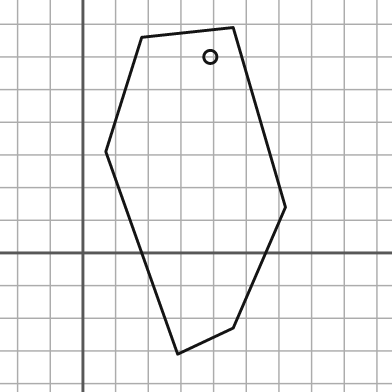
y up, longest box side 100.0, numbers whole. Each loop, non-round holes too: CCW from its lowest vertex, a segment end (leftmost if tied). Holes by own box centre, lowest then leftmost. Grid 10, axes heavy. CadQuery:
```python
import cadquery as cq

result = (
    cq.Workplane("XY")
    .moveTo(29.0, -31.0)
    .lineTo(46.0, -23.0)
    .lineTo(62.0, 14.0)
    .lineTo(46.0, 69.0)
    .lineTo(18.0, 66.0)
    .lineTo(7.0, 31.0)
    .close()
    .moveTo(39.0, 60.0)
    .circle(2.0)
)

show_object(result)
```